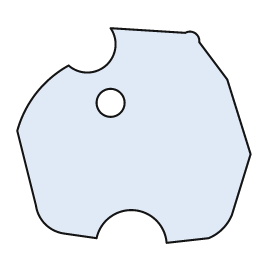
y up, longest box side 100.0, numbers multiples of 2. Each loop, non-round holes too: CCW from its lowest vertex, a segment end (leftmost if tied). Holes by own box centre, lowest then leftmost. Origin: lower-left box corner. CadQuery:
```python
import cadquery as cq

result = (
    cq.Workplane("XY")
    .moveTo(64.0, 0.0)
    .lineTo(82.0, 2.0)
    .threePointArc((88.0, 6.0), (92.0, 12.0))
    .lineTo(100.0, 38.0)
    .lineTo(90.0, 70.0)
    .lineTo(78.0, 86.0)
    .threePointArc((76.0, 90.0), (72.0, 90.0))
    .lineTo(40.0, 92.0)
    .threePointArc((38.0, 76.0), (22.0, 76.0))
    .threePointArc((8.0, 64.0), (0.0, 48.0))
    .lineTo(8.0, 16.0)
    .threePointArc((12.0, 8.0), (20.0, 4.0))
    .lineTo(34.0, 2.0)
    .threePointArc((50.0, 14.0), (64.0, 0.0))
    .close()
    .moveTo(40.0, 60.0)
    .circle(6.0)
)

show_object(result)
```